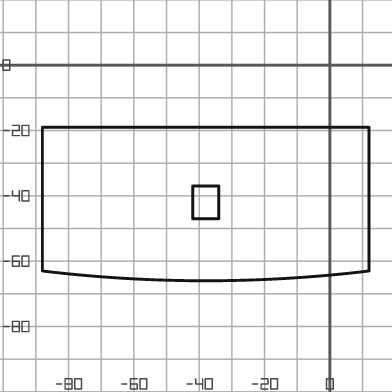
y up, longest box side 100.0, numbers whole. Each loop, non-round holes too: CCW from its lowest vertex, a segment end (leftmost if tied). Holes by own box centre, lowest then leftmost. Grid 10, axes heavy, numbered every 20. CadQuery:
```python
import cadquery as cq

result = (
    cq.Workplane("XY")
    .moveTo(-88.0, -63.0)
    .threePointArc((-38.0, -66.0), (12.0, -63.0))
    .lineTo(12.0, -19.0)
    .lineTo(-88.0, -19.0)
    .close()
    .moveTo(-42.0, -47.0)
    .lineTo(-34.0, -47.0)
    .lineTo(-34.0, -37.0)
    .lineTo(-42.0, -37.0)
    .close()
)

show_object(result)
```